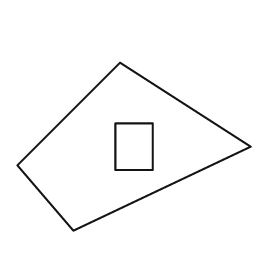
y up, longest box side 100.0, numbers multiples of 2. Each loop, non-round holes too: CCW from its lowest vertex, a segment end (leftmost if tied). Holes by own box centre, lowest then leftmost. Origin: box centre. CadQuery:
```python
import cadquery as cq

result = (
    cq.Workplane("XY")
    .moveTo(-26.0, -36.0)
    .lineTo(50.0, 0.0)
    .lineTo(-6.0, 36.0)
    .lineTo(-50.0, -8.0)
    .close()
    .moveTo(-8.0, -10.0)
    .lineTo(8.0, -10.0)
    .lineTo(8.0, 10.0)
    .lineTo(-8.0, 10.0)
    .close()
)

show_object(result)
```